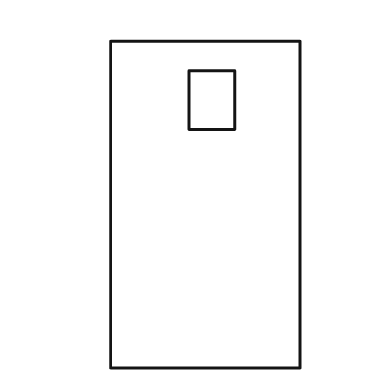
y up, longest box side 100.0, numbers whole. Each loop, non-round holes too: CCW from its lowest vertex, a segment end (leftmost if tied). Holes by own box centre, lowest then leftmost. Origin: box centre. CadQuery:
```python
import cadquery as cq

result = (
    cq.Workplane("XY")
    .moveTo(-29.0, -50.0)
    .lineTo(29.0, -50.0)
    .lineTo(29.0, 50.0)
    .lineTo(-29.0, 50.0)
    .close()
    .moveTo(-5.0, 23.0)
    .lineTo(9.0, 23.0)
    .lineTo(9.0, 41.0)
    .lineTo(-5.0, 41.0)
    .close()
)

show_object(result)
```